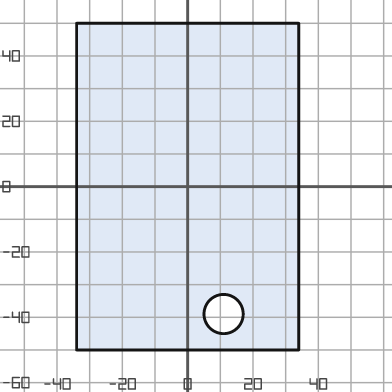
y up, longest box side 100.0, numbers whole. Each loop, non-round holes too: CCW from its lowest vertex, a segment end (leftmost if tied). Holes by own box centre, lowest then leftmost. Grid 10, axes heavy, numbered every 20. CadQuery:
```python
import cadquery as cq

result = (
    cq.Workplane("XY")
    .moveTo(-34.0, -50.0)
    .lineTo(34.0, -50.0)
    .lineTo(34.0, 50.0)
    .lineTo(-34.0, 50.0)
    .close()
    .moveTo(11.0, -39.0)
    .circle(6.0)
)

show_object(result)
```